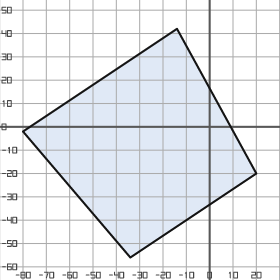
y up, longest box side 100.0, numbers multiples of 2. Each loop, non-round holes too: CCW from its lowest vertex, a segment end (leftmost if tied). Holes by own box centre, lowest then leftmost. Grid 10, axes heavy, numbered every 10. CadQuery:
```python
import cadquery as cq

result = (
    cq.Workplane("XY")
    .moveTo(-34.0, -56.0)
    .lineTo(20.0, -20.0)
    .lineTo(-14.0, 42.0)
    .lineTo(-80.0, -2.0)
    .close()
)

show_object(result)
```